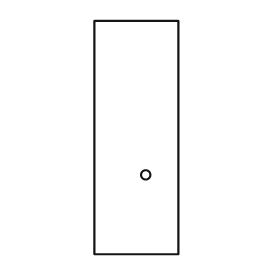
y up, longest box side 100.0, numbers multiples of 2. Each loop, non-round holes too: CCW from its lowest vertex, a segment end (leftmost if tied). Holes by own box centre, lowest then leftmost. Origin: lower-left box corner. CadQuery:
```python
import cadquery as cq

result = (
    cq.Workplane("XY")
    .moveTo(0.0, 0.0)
    .lineTo(36.0, 0.0)
    .lineTo(36.0, 100.0)
    .lineTo(0.0, 100.0)
    .close()
    .moveTo(22.0, 34.0)
    .circle(2.0)
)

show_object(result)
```